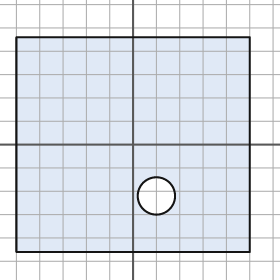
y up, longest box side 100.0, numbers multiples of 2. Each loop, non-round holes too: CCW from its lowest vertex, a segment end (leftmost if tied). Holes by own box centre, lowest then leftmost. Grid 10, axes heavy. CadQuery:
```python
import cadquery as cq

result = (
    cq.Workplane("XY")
    .moveTo(-50.0, -46.0)
    .lineTo(50.0, -46.0)
    .lineTo(50.0, 46.0)
    .lineTo(-50.0, 46.0)
    .close()
    .moveTo(10.0, -22.0)
    .circle(8.0)
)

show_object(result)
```